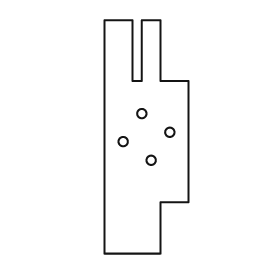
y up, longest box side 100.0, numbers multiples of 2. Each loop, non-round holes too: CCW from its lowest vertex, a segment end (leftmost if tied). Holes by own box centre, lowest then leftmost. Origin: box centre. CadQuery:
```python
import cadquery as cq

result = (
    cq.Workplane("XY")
    .moveTo(-18.0, -50.0)
    .lineTo(6.0, -50.0)
    .lineTo(6.0, -28.0)
    .lineTo(18.0, -28.0)
    .lineTo(18.0, 24.0)
    .lineTo(6.0, 24.0)
    .lineTo(6.0, 50.0)
    .lineTo(-2.0, 50.0)
    .lineTo(-2.0, 24.0)
    .lineTo(-6.0, 24.0)
    .lineTo(-6.0, 50.0)
    .lineTo(-18.0, 50.0)
    .close()
    .moveTo(2.0, -10.0)
    .circle(2.0)
    .moveTo(-10.0, -2.0)
    .circle(2.0)
    .moveTo(10.0, 2.0)
    .circle(2.0)
    .moveTo(-2.0, 10.0)
    .circle(2.0)
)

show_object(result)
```